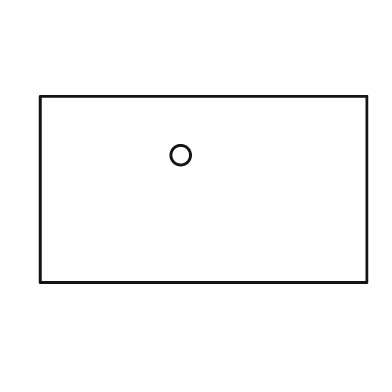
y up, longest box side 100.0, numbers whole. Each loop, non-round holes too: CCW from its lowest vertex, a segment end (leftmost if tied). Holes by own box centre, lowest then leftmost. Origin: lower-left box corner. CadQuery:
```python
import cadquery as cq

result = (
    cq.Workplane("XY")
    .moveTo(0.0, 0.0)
    .lineTo(100.0, 0.0)
    .lineTo(100.0, 57.0)
    .lineTo(0.0, 57.0)
    .close()
    .moveTo(43.0, 39.0)
    .circle(3.0)
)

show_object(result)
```